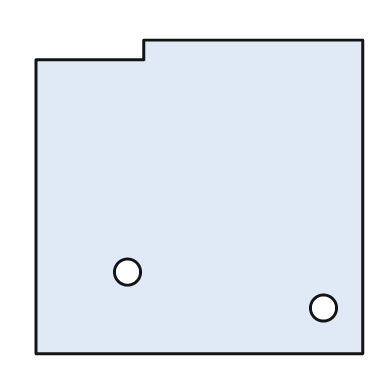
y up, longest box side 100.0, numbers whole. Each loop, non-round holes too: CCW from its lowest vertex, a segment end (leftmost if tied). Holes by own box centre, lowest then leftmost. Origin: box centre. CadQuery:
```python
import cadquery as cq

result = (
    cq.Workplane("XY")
    .moveTo(-50.0, -48.0)
    .lineTo(50.0, -48.0)
    .lineTo(50.0, 48.0)
    .lineTo(-17.0, 48.0)
    .lineTo(-17.0, 42.0)
    .lineTo(-50.0, 42.0)
    .close()
    .moveTo(38.0, -34.0)
    .circle(4.0)
    .moveTo(-22.0, -23.0)
    .circle(4.0)
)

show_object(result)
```